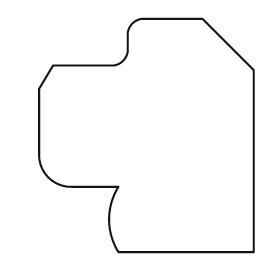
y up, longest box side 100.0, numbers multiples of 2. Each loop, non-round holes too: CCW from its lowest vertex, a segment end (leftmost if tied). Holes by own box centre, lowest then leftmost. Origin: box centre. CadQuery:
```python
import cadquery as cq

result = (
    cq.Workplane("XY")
    .moveTo(-12.0, -50.0)
    .lineTo(46.0, -50.0)
    .lineTo(46.0, 28.0)
    .lineTo(24.0, 50.0)
    .lineTo(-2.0, 50.0)
    .threePointArc((-6.0, 48.0), (-8.0, 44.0))
    .lineTo(-8.0, 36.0)
    .threePointArc((-10.0, 32.0), (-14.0, 30.0))
    .lineTo(-40.0, 30.0)
    .lineTo(-46.0, 20.0)
    .lineTo(-46.0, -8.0)
    .threePointArc((-42.0, -18.0), (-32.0, -22.0))
    .lineTo(-12.0, -22.0)
    .threePointArc((-16.0, -36.0), (-12.0, -50.0))
    .close()
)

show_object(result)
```